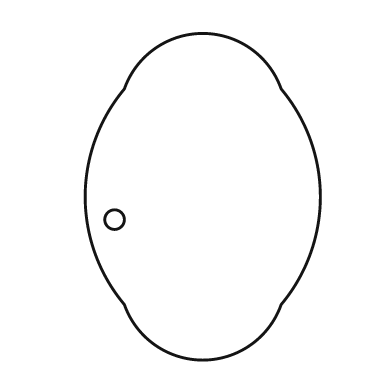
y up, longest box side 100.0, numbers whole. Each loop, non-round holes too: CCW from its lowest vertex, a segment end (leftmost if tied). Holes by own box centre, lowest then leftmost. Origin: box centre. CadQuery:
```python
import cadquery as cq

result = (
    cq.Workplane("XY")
    .moveTo(-24.0, -33.0)
    .threePointArc((0.0, -50.0), (24.0, -33.0))
    .threePointArc((36.0, 0.0), (24.0, 33.0))
    .threePointArc((0.0, 50.0), (-24.0, 33.0))
    .threePointArc((-36.0, 0.0), (-24.0, -33.0))
    .close()
    .moveTo(-27.0, -7.0)
    .circle(3.0)
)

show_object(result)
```